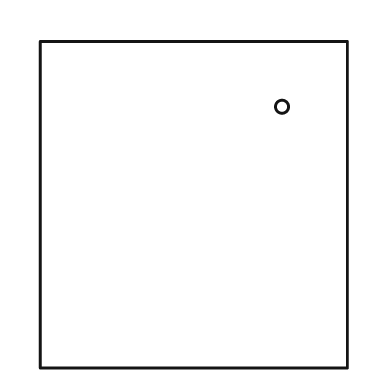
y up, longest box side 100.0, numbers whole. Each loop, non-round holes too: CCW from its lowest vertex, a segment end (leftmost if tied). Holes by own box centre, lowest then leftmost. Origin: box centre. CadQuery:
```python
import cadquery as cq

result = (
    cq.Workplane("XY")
    .moveTo(-47.0, -50.0)
    .lineTo(47.0, -50.0)
    .lineTo(47.0, 50.0)
    .lineTo(-47.0, 50.0)
    .close()
    .moveTo(27.0, 30.0)
    .circle(2.0)
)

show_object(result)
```